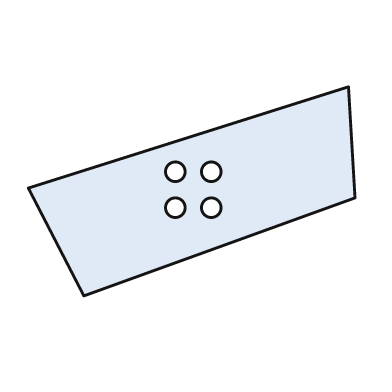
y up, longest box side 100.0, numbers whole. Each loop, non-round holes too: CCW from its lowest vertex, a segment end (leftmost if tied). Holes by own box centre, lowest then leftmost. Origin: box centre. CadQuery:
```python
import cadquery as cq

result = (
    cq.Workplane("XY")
    .moveTo(-33.0, -32.0)
    .lineTo(50.0, -2.0)
    .lineTo(48.0, 32.0)
    .lineTo(-50.0, 1.0)
    .close()
    .moveTo(-5.0, -5.0)
    .circle(3.0)
    .moveTo(6.0, -5.0)
    .circle(3.0)
    .moveTo(-5.0, 6.0)
    .circle(3.0)
    .moveTo(6.0, 6.0)
    .circle(3.0)
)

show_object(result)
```